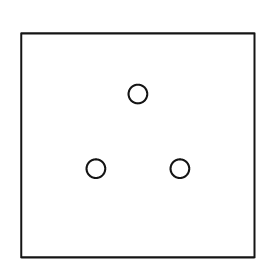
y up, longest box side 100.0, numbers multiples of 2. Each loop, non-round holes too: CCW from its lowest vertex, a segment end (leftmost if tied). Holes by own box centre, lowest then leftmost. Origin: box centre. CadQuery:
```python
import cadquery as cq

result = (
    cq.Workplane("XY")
    .moveTo(-50.0, -48.0)
    .lineTo(50.0, -48.0)
    .lineTo(50.0, 48.0)
    .lineTo(-50.0, 48.0)
    .close()
    .moveTo(-18.0, -10.0)
    .circle(4.0)
    .moveTo(18.0, -10.0)
    .circle(4.0)
    .moveTo(0.0, 22.0)
    .circle(4.0)
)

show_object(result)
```